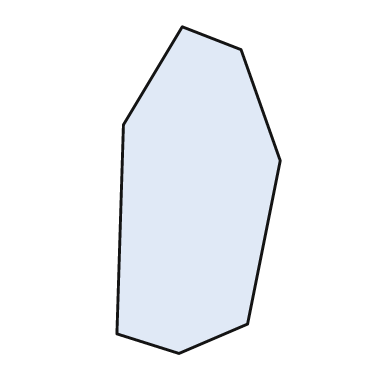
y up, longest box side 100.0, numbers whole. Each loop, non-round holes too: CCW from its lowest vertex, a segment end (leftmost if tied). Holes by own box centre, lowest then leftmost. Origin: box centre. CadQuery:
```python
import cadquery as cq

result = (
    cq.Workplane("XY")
    .moveTo(-6.0, -50.0)
    .lineTo(15.0, -41.0)
    .lineTo(25.0, 9.0)
    .lineTo(13.0, 43.0)
    .lineTo(-5.0, 50.0)
    .lineTo(-23.0, 20.0)
    .lineTo(-25.0, -44.0)
    .close()
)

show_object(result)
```